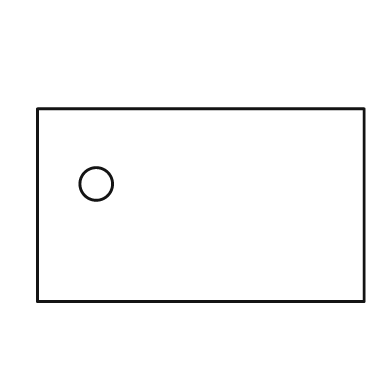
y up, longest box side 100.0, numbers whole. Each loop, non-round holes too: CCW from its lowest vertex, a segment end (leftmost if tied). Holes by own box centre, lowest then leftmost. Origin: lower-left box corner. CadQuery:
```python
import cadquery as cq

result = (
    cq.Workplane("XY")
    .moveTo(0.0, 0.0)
    .lineTo(100.0, 0.0)
    .lineTo(100.0, 59.0)
    .lineTo(0.0, 59.0)
    .close()
    .moveTo(18.0, 36.0)
    .circle(5.0)
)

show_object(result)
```